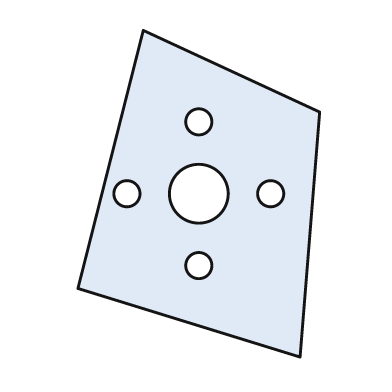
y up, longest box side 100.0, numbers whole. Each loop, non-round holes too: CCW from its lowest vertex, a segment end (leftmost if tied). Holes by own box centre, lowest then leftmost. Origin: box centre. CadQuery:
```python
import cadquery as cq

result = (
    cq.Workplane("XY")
    .moveTo(31.0, -50.0)
    .lineTo(37.0, 25.0)
    .lineTo(-17.0, 50.0)
    .lineTo(-37.0, -29.0)
    .close()
    .moveTo(0.0, -22.0)
    .circle(4.0)
    .moveTo(-22.0, 0.0)
    .circle(4.0)
    .moveTo(0.0, 0.0)
    .circle(9.0)
    .moveTo(22.0, 0.0)
    .circle(4.0)
    .moveTo(0.0, 22.0)
    .circle(4.0)
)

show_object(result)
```